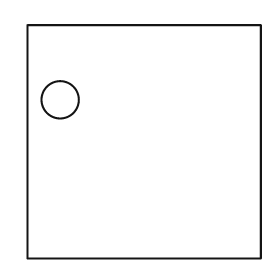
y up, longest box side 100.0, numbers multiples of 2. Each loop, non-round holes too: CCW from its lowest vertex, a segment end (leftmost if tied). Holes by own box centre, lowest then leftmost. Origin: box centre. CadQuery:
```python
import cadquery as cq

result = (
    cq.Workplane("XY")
    .moveTo(-50.0, -50.0)
    .lineTo(50.0, -50.0)
    .lineTo(50.0, 50.0)
    .lineTo(-50.0, 50.0)
    .close()
    .moveTo(-36.0, 18.0)
    .circle(8.0)
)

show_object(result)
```